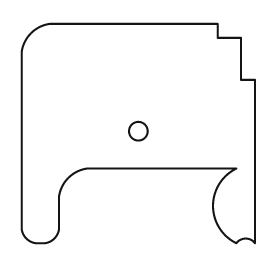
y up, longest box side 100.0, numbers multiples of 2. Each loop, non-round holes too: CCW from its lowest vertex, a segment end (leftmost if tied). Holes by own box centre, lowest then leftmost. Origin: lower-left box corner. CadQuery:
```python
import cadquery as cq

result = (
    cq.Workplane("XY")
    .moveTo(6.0, 0.0)
    .lineTo(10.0, 0.0)
    .threePointArc((14.0, 2.0), (16.0, 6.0))
    .lineTo(16.0, 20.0)
    .threePointArc((20.0, 28.0), (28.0, 32.0))
    .lineTo(92.0, 32.0)
    .threePointArc((82.0, 16.0), (92.0, 0.0))
    .threePointArc((96.0, 2.0), (100.0, 0.0))
    .lineTo(100.0, 70.0)
    .lineTo(94.0, 70.0)
    .lineTo(94.0, 88.0)
    .lineTo(84.0, 88.0)
    .lineTo(84.0, 94.0)
    .lineTo(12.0, 94.0)
    .threePointArc((4.0, 90.0), (0.0, 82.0))
    .lineTo(0.0, 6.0)
    .threePointArc((2.0, 2.0), (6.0, 0.0))
    .close()
    .moveTo(50.0, 48.0)
    .circle(4.0)
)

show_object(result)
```